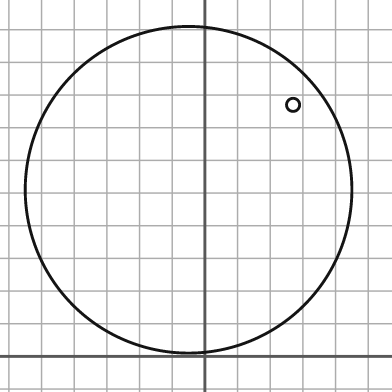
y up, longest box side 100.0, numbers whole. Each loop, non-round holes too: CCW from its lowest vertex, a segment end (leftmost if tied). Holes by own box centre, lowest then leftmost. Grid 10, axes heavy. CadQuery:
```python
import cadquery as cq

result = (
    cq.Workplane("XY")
    .moveTo(-5.0, 51.0)
    .circle(50.0)
    .moveTo(27.0, 77.0)
    .circle(2.0)
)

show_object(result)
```